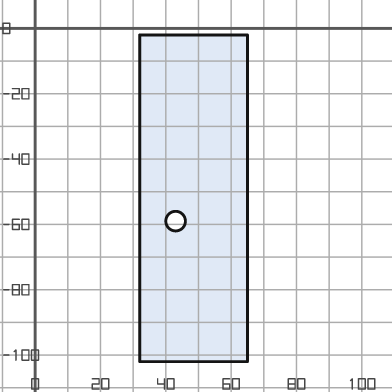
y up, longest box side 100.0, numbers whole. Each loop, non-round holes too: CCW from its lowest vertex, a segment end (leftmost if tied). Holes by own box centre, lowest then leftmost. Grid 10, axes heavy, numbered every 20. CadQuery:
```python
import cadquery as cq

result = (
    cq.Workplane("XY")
    .moveTo(32.0, -102.0)
    .lineTo(65.0, -102.0)
    .lineTo(65.0, -2.0)
    .lineTo(32.0, -2.0)
    .close()
    .moveTo(43.0, -59.0)
    .circle(3.0)
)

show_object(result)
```